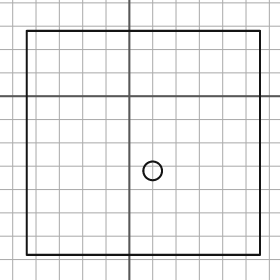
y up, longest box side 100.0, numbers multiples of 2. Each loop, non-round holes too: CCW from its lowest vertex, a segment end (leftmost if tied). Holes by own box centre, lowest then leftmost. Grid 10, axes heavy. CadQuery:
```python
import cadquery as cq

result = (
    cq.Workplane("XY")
    .moveTo(-44.0, -68.0)
    .lineTo(56.0, -68.0)
    .lineTo(56.0, 28.0)
    .lineTo(-44.0, 28.0)
    .close()
    .moveTo(10.0, -32.0)
    .circle(4.0)
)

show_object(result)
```